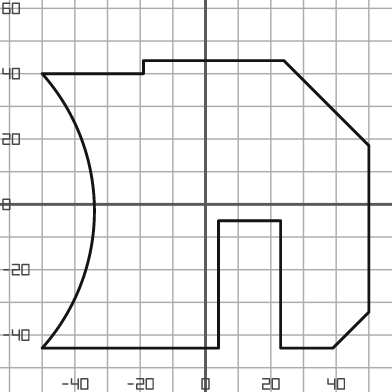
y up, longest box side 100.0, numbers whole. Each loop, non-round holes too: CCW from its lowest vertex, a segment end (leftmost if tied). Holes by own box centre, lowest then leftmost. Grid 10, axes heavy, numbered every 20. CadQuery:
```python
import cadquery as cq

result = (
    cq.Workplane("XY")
    .moveTo(-50.0, -44.0)
    .lineTo(4.0, -44.0)
    .lineTo(4.0, -5.0)
    .lineTo(23.0, -5.0)
    .lineTo(23.0, -44.0)
    .lineTo(39.0, -44.0)
    .lineTo(50.0, -33.0)
    .lineTo(50.0, 18.0)
    .lineTo(24.0, 44.0)
    .lineTo(-19.0, 44.0)
    .lineTo(-19.0, 40.0)
    .lineTo(-50.0, 40.0)
    .threePointArc((-34.0, -2.0), (-50.0, -44.0))
    .close()
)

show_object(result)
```